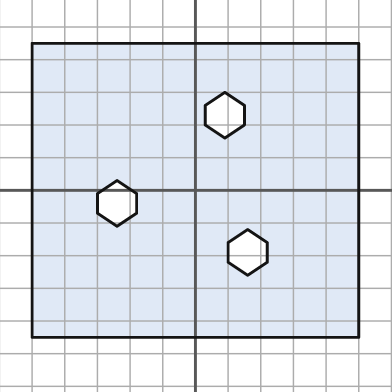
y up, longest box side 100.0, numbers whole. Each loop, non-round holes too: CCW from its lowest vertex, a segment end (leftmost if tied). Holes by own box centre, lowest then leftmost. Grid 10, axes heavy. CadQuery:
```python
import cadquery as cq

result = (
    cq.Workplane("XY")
    .moveTo(-50.0, -45.0)
    .lineTo(50.0, -45.0)
    .lineTo(50.0, 45.0)
    .lineTo(-50.0, 45.0)
    .close()
    .moveTo(16.0, -26.0)
    .lineTo(22.0, -22.0)
    .lineTo(22.0, -16.0)
    .lineTo(16.0, -12.0)
    .lineTo(10.0, -16.0)
    .lineTo(10.0, -22.0)
    .close()
    .moveTo(-24.0, -11.0)
    .lineTo(-18.0, -7.0)
    .lineTo(-18.0, -1.0)
    .lineTo(-24.0, 3.0)
    .lineTo(-30.0, -1.0)
    .lineTo(-30.0, -7.0)
    .close()
    .moveTo(9.0, 16.0)
    .lineTo(15.0, 20.0)
    .lineTo(15.0, 26.0)
    .lineTo(9.0, 30.0)
    .lineTo(3.0, 26.0)
    .lineTo(3.0, 20.0)
    .close()
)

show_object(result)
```